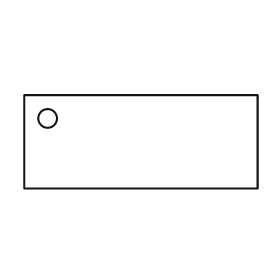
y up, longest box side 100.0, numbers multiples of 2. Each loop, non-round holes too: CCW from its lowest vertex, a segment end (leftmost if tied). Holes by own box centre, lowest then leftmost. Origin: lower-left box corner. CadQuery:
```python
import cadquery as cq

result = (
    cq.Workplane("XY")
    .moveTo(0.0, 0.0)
    .lineTo(100.0, 0.0)
    .lineTo(100.0, 40.0)
    .lineTo(0.0, 40.0)
    .close()
    .moveTo(10.0, 30.0)
    .circle(4.0)
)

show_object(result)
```